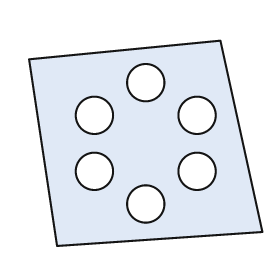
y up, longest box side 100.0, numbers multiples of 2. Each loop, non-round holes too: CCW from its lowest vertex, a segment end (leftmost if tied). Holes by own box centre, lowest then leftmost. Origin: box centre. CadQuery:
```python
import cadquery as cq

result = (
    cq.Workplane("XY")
    .moveTo(-38.0, -44.0)
    .lineTo(50.0, -38.0)
    .lineTo(32.0, 44.0)
    .lineTo(-50.0, 36.0)
    .close()
    .moveTo(0.0, -26.0)
    .circle(8.0)
    .moveTo(-22.0, -12.0)
    .circle(8.0)
    .moveTo(22.0, -12.0)
    .circle(8.0)
    .moveTo(-22.0, 12.0)
    .circle(8.0)
    .moveTo(22.0, 12.0)
    .circle(8.0)
    .moveTo(0.0, 26.0)
    .circle(8.0)
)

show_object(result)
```